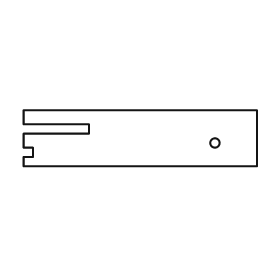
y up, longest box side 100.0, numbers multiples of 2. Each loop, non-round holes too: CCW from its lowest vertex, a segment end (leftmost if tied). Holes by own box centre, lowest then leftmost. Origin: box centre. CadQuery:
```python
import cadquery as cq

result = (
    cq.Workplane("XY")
    .moveTo(-50.0, -12.0)
    .lineTo(50.0, -12.0)
    .lineTo(50.0, 12.0)
    .lineTo(-50.0, 12.0)
    .lineTo(-50.0, 6.0)
    .lineTo(-22.0, 6.0)
    .lineTo(-22.0, 2.0)
    .lineTo(-50.0, 2.0)
    .lineTo(-50.0, -4.0)
    .lineTo(-46.0, -4.0)
    .lineTo(-46.0, -8.0)
    .lineTo(-50.0, -8.0)
    .close()
    .moveTo(32.0, -2.0)
    .circle(2.0)
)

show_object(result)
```